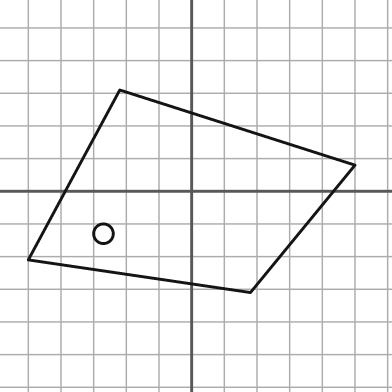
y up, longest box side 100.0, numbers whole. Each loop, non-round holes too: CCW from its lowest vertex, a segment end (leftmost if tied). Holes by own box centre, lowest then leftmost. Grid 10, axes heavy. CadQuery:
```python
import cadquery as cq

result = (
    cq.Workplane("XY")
    .moveTo(18.0, -31.0)
    .lineTo(50.0, 8.0)
    .lineTo(-22.0, 31.0)
    .lineTo(-50.0, -21.0)
    .close()
    .moveTo(-27.0, -13.0)
    .circle(3.0)
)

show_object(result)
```